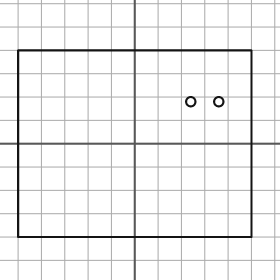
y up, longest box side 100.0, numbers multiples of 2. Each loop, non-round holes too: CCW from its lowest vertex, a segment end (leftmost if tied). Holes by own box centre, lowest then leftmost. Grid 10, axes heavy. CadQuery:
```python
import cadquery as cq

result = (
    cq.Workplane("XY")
    .moveTo(-50.0, -40.0)
    .lineTo(50.0, -40.0)
    .lineTo(50.0, 40.0)
    .lineTo(-50.0, 40.0)
    .close()
    .moveTo(24.0, 18.0)
    .circle(2.0)
    .moveTo(36.0, 18.0)
    .circle(2.0)
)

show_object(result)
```